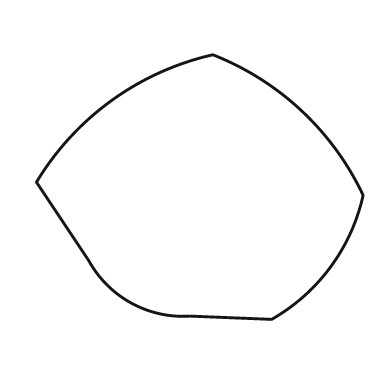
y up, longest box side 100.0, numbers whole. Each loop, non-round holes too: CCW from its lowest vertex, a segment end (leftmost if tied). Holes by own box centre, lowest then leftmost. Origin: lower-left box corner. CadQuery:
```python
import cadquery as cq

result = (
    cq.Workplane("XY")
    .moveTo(72.0, 0.0)
    .threePointArc((90.0, 16.0), (100.0, 38.0))
    .threePointArc((81.0, 64.0), (54.0, 81.0))
    .threePointArc((23.0, 67.0), (0.0, 42.0))
    .lineTo(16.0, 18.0)
    .threePointArc((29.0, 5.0), (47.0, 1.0))
    .close()
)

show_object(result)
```